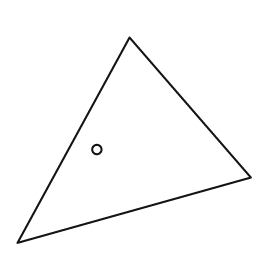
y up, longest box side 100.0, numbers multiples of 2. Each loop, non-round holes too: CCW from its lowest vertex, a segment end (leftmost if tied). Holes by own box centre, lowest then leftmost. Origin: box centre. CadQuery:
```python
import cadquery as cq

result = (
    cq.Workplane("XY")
    .moveTo(-50.0, -44.0)
    .lineTo(50.0, -16.0)
    .lineTo(-2.0, 44.0)
    .close()
    .moveTo(-16.0, -4.0)
    .circle(2.0)
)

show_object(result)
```